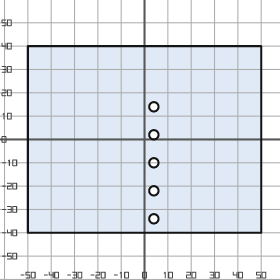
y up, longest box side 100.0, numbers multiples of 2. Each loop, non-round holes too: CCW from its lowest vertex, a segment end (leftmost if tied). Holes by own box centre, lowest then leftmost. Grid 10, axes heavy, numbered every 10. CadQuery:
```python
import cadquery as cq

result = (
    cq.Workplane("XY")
    .moveTo(-50.0, -40.0)
    .lineTo(50.0, -40.0)
    .lineTo(50.0, 40.0)
    .lineTo(-50.0, 40.0)
    .close()
    .moveTo(4.0, -34.0)
    .circle(2.0)
    .moveTo(4.0, -22.0)
    .circle(2.0)
    .moveTo(4.0, -10.0)
    .circle(2.0)
    .moveTo(4.0, 2.0)
    .circle(2.0)
    .moveTo(4.0, 14.0)
    .circle(2.0)
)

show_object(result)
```